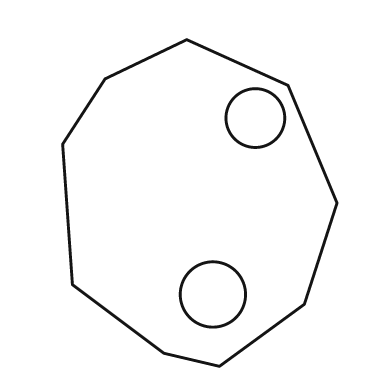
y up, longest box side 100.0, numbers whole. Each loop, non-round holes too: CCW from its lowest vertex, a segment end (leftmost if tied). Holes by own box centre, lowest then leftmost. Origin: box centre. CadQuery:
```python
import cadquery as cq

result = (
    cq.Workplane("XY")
    .moveTo(6.0, -50.0)
    .lineTo(32.0, -31.0)
    .lineTo(42.0, 0.0)
    .lineTo(27.0, 36.0)
    .lineTo(-4.0, 50.0)
    .lineTo(-29.0, 38.0)
    .lineTo(-42.0, 18.0)
    .lineTo(-39.0, -25.0)
    .lineTo(-11.0, -46.0)
    .close()
    .moveTo(4.0, -28.0)
    .circle(10.0)
    .moveTo(17.0, 26.0)
    .circle(9.0)
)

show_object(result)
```